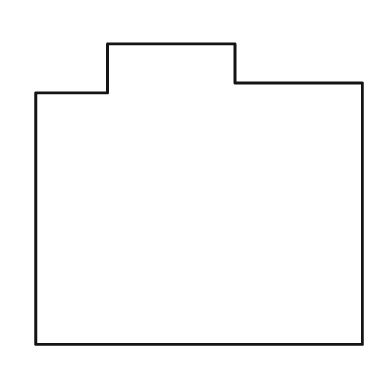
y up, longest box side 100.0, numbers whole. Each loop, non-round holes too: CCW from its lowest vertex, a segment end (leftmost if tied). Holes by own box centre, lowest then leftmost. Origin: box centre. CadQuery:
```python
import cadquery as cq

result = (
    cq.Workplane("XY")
    .moveTo(-50.0, -46.0)
    .lineTo(50.0, -46.0)
    .lineTo(50.0, 34.0)
    .lineTo(11.0, 34.0)
    .lineTo(11.0, 46.0)
    .lineTo(-28.0, 46.0)
    .lineTo(-28.0, 31.0)
    .lineTo(-50.0, 31.0)
    .close()
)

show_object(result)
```